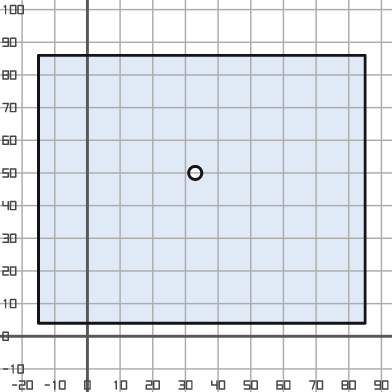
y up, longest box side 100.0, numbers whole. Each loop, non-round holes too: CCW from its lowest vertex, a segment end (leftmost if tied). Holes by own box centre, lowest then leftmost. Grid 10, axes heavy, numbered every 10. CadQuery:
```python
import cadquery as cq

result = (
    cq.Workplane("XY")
    .moveTo(-15.0, 4.0)
    .lineTo(85.0, 4.0)
    .lineTo(85.0, 86.0)
    .lineTo(-15.0, 86.0)
    .close()
    .moveTo(33.0, 50.0)
    .circle(2.0)
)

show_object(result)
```